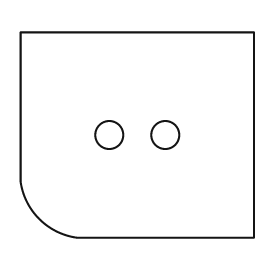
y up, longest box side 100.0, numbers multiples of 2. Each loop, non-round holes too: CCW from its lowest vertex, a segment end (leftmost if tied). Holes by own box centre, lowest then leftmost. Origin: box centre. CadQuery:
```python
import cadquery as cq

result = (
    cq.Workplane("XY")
    .moveTo(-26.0, -44.0)
    .lineTo(50.0, -44.0)
    .lineTo(50.0, 44.0)
    .lineTo(-50.0, 44.0)
    .lineTo(-50.0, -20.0)
    .threePointArc((-42.0, -36.0), (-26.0, -44.0))
    .close()
    .moveTo(-12.0, 0.0)
    .circle(6.0)
    .moveTo(12.0, 0.0)
    .circle(6.0)
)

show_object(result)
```